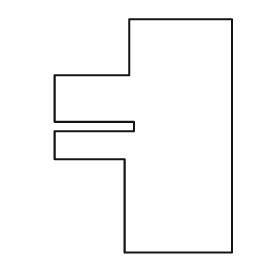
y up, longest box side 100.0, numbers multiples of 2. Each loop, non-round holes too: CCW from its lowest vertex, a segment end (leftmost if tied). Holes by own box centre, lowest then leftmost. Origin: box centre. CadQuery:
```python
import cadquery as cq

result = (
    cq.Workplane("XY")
    .moveTo(-8.0, -50.0)
    .lineTo(38.0, -50.0)
    .lineTo(38.0, 50.0)
    .lineTo(-6.0, 50.0)
    .lineTo(-6.0, 26.0)
    .lineTo(-38.0, 26.0)
    .lineTo(-38.0, 6.0)
    .lineTo(-4.0, 6.0)
    .lineTo(-4.0, 2.0)
    .lineTo(-38.0, 2.0)
    .lineTo(-38.0, -10.0)
    .lineTo(-8.0, -10.0)
    .close()
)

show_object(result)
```